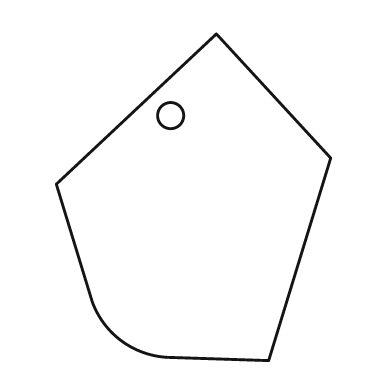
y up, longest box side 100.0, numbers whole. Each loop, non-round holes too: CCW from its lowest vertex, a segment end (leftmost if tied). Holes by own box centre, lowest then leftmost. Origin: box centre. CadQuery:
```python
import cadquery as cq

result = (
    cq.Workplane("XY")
    .moveTo(23.0, -50.0)
    .lineTo(42.0, 12.0)
    .lineTo(7.0, 50.0)
    .lineTo(-42.0, 4.0)
    .lineTo(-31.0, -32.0)
    .threePointArc((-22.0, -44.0), (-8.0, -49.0))
    .close()
    .moveTo(-7.0, 25.0)
    .circle(4.0)
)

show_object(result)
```